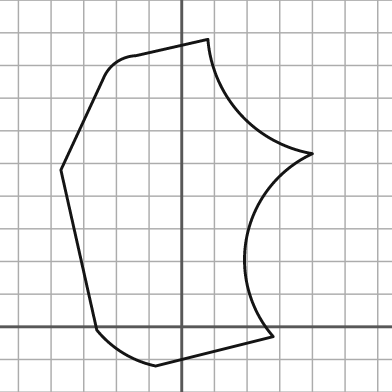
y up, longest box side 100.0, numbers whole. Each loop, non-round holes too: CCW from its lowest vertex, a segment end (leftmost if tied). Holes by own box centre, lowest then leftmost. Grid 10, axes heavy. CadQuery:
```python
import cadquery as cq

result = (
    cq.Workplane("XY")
    .moveTo(-8.0, -12.0)
    .lineTo(28.0, -3.0)
    .threePointArc((20.0, 28.0), (40.0, 53.0))
    .threePointArc((18.0, 65.0), (8.0, 88.0))
    .lineTo(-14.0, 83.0)
    .threePointArc((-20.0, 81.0), (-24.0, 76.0))
    .lineTo(-37.0, 48.0)
    .lineTo(-26.0, -1.0)
    .threePointArc((-18.0, -8.0), (-8.0, -12.0))
    .close()
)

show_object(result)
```